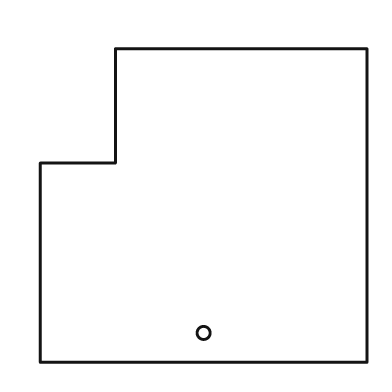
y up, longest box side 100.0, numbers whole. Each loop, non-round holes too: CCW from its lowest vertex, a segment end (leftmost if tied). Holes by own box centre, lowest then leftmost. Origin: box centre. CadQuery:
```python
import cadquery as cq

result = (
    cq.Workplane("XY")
    .moveTo(-50.0, -48.0)
    .lineTo(50.0, -48.0)
    .lineTo(50.0, 48.0)
    .lineTo(-27.0, 48.0)
    .lineTo(-27.0, 13.0)
    .lineTo(-50.0, 13.0)
    .close()
    .moveTo(0.0, -39.0)
    .circle(2.0)
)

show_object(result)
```